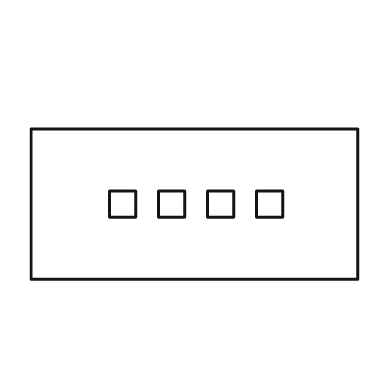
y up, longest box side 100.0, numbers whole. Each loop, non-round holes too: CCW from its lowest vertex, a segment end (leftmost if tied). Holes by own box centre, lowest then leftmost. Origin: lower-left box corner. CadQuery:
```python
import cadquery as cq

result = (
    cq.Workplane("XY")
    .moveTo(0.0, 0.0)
    .lineTo(100.0, 0.0)
    .lineTo(100.0, 46.0)
    .lineTo(0.0, 46.0)
    .close()
    .moveTo(24.0, 19.0)
    .lineTo(32.0, 19.0)
    .lineTo(32.0, 27.0)
    .lineTo(24.0, 27.0)
    .close()
    .moveTo(39.0, 19.0)
    .lineTo(47.0, 19.0)
    .lineTo(47.0, 27.0)
    .lineTo(39.0, 27.0)
    .close()
    .moveTo(54.0, 19.0)
    .lineTo(62.0, 19.0)
    .lineTo(62.0, 27.0)
    .lineTo(54.0, 27.0)
    .close()
    .moveTo(69.0, 19.0)
    .lineTo(77.0, 19.0)
    .lineTo(77.0, 27.0)
    .lineTo(69.0, 27.0)
    .close()
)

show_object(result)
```